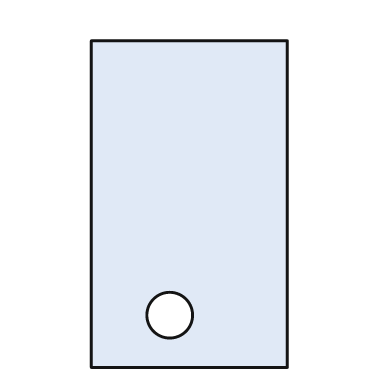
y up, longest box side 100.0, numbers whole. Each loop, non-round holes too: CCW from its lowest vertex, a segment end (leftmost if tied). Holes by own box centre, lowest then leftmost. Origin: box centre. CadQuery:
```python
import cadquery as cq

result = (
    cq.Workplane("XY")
    .moveTo(-30.0, -50.0)
    .lineTo(30.0, -50.0)
    .lineTo(30.0, 50.0)
    .lineTo(-30.0, 50.0)
    .close()
    .moveTo(-6.0, -34.0)
    .circle(7.0)
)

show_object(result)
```